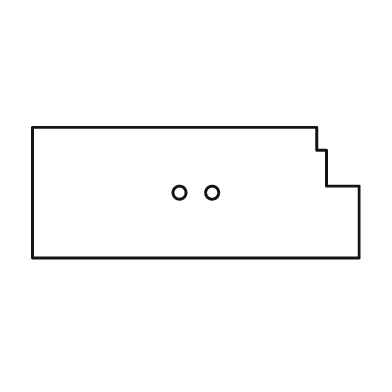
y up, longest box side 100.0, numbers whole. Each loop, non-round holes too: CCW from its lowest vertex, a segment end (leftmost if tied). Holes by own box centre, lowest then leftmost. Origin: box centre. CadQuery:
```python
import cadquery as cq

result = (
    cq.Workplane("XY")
    .moveTo(-50.0, -20.0)
    .lineTo(50.0, -20.0)
    .lineTo(50.0, 2.0)
    .lineTo(40.0, 2.0)
    .lineTo(40.0, 13.0)
    .lineTo(37.0, 13.0)
    .lineTo(37.0, 20.0)
    .lineTo(-50.0, 20.0)
    .close()
    .moveTo(-5.0, 0.0)
    .circle(2.0)
    .moveTo(5.0, 0.0)
    .circle(2.0)
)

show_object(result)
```